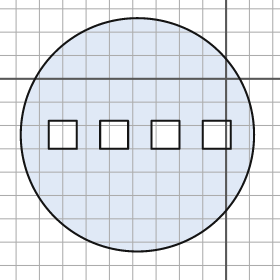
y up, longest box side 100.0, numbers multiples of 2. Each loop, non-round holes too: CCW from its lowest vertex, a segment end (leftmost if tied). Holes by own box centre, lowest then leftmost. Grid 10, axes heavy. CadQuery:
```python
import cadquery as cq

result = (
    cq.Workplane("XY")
    .moveTo(-38.0, -24.0)
    .circle(50.0)
    .moveTo(-76.0, -30.0)
    .lineTo(-64.0, -30.0)
    .lineTo(-64.0, -18.0)
    .lineTo(-76.0, -18.0)
    .close()
    .moveTo(-54.0, -30.0)
    .lineTo(-42.0, -30.0)
    .lineTo(-42.0, -18.0)
    .lineTo(-54.0, -18.0)
    .close()
    .moveTo(-32.0, -30.0)
    .lineTo(-20.0, -30.0)
    .lineTo(-20.0, -18.0)
    .lineTo(-32.0, -18.0)
    .close()
    .moveTo(-10.0, -30.0)
    .lineTo(2.0, -30.0)
    .lineTo(2.0, -18.0)
    .lineTo(-10.0, -18.0)
    .close()
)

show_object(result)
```